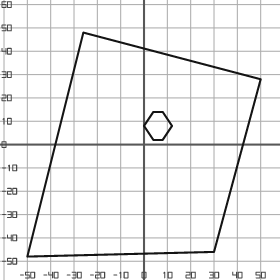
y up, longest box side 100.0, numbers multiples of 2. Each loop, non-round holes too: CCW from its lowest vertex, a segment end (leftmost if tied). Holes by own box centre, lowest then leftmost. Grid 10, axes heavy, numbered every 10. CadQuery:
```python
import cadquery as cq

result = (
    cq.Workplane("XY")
    .moveTo(-50.0, -48.0)
    .lineTo(30.0, -46.0)
    .lineTo(50.0, 28.0)
    .lineTo(-26.0, 48.0)
    .close()
    .moveTo(4.0, 2.0)
    .lineTo(8.0, 2.0)
    .lineTo(12.0, 8.0)
    .lineTo(8.0, 14.0)
    .lineTo(4.0, 14.0)
    .lineTo(0.0, 8.0)
    .close()
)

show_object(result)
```